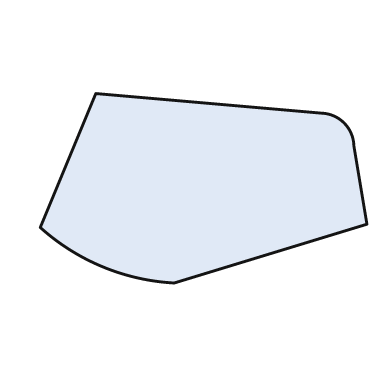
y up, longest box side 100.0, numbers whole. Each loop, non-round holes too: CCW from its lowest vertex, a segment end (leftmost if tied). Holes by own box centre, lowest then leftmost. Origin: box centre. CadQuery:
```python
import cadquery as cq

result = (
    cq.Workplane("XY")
    .moveTo(-9.0, -29.0)
    .lineTo(50.0, -11.0)
    .lineTo(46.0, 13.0)
    .threePointArc((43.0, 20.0), (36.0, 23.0))
    .lineTo(-33.0, 29.0)
    .lineTo(-50.0, -12.0)
    .threePointArc((-31.0, -24.0), (-9.0, -29.0))
    .close()
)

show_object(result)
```